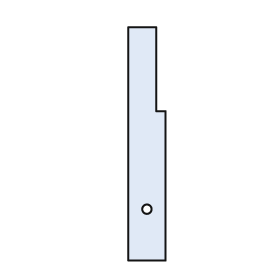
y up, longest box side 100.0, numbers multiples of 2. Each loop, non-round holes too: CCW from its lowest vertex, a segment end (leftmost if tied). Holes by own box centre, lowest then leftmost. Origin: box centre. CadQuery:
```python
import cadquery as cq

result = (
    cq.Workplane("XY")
    .moveTo(-8.0, -50.0)
    .lineTo(8.0, -50.0)
    .lineTo(8.0, 14.0)
    .lineTo(4.0, 14.0)
    .lineTo(4.0, 50.0)
    .lineTo(-8.0, 50.0)
    .close()
    .moveTo(0.0, -28.0)
    .circle(2.0)
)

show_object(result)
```